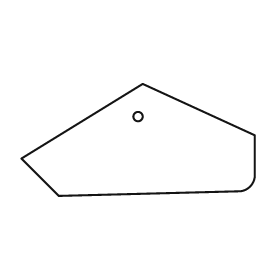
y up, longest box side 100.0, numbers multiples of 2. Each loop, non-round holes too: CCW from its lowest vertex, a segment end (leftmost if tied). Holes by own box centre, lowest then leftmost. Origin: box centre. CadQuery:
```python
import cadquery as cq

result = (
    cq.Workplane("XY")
    .moveTo(-34.0, -24.0)
    .lineTo(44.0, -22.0)
    .threePointArc((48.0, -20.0), (50.0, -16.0))
    .lineTo(50.0, 2.0)
    .lineTo(2.0, 24.0)
    .lineTo(-50.0, -8.0)
    .close()
    .moveTo(0.0, 10.0)
    .circle(2.0)
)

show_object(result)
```